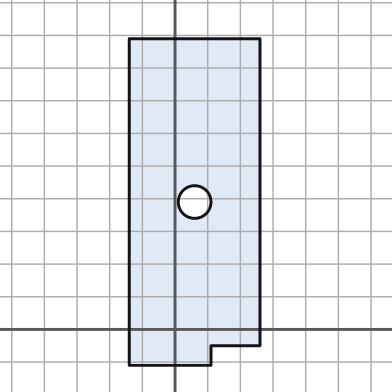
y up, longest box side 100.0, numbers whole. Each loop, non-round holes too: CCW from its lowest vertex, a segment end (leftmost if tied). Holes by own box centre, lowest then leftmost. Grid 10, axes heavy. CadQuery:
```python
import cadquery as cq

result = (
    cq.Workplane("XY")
    .moveTo(-14.0, -11.0)
    .lineTo(11.0, -11.0)
    .lineTo(11.0, -5.0)
    .lineTo(26.0, -5.0)
    .lineTo(26.0, 89.0)
    .lineTo(-14.0, 89.0)
    .close()
    .moveTo(6.0, 39.0)
    .circle(5.0)
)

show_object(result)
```